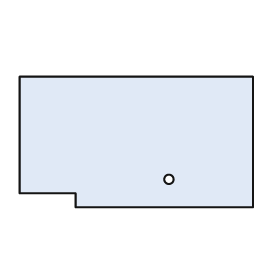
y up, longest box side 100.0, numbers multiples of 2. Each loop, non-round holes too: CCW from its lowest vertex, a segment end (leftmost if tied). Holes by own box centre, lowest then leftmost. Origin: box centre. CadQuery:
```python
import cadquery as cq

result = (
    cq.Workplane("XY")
    .moveTo(-26.0, -28.0)
    .lineTo(50.0, -28.0)
    .lineTo(50.0, 28.0)
    .lineTo(-50.0, 28.0)
    .lineTo(-50.0, -22.0)
    .lineTo(-26.0, -22.0)
    .close()
    .moveTo(14.0, -16.0)
    .circle(2.0)
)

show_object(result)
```